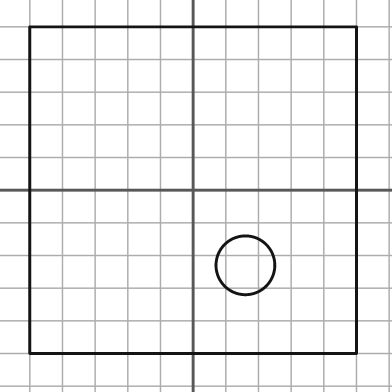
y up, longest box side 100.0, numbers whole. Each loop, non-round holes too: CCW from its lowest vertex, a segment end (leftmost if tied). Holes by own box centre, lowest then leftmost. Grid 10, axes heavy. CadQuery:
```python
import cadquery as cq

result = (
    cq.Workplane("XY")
    .moveTo(-50.0, -50.0)
    .lineTo(50.0, -50.0)
    .lineTo(50.0, 50.0)
    .lineTo(-50.0, 50.0)
    .close()
    .moveTo(16.0, -23.0)
    .circle(9.0)
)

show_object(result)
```